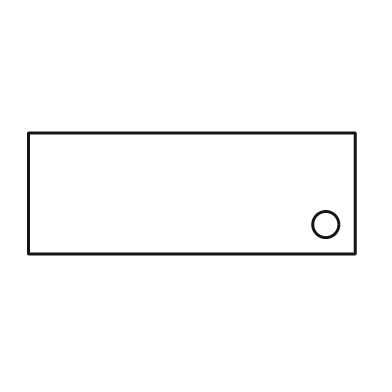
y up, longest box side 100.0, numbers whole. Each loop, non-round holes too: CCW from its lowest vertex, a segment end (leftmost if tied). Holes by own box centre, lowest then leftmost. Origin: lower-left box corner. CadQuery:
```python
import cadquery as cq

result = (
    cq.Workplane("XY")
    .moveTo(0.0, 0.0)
    .lineTo(100.0, 0.0)
    .lineTo(100.0, 37.0)
    .lineTo(0.0, 37.0)
    .close()
    .moveTo(91.0, 9.0)
    .circle(4.0)
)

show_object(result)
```